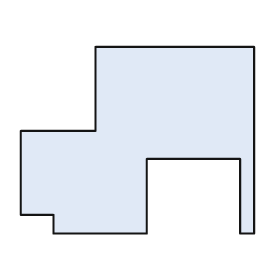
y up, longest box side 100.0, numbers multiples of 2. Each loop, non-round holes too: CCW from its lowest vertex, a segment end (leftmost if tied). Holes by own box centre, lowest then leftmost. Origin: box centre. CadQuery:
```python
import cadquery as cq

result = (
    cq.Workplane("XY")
    .moveTo(-36.0, -40.0)
    .lineTo(4.0, -40.0)
    .lineTo(4.0, -8.0)
    .lineTo(44.0, -8.0)
    .lineTo(44.0, -40.0)
    .lineTo(50.0, -40.0)
    .lineTo(50.0, 40.0)
    .lineTo(-18.0, 40.0)
    .lineTo(-18.0, 4.0)
    .lineTo(-50.0, 4.0)
    .lineTo(-50.0, -32.0)
    .lineTo(-36.0, -32.0)
    .close()
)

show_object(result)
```